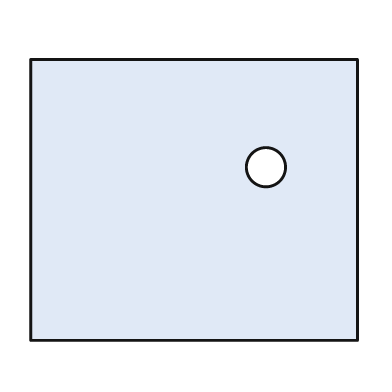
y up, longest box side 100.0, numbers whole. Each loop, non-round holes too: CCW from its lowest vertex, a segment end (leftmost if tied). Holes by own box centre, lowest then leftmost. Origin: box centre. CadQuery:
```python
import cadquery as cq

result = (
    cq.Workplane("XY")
    .moveTo(-50.0, -43.0)
    .lineTo(50.0, -43.0)
    .lineTo(50.0, 43.0)
    .lineTo(-50.0, 43.0)
    .close()
    .moveTo(22.0, 10.0)
    .circle(6.0)
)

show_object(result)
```